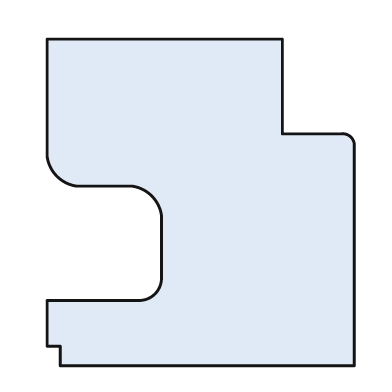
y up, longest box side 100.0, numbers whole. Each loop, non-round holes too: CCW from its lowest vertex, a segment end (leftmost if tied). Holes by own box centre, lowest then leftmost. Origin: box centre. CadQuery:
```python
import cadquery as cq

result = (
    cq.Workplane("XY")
    .moveTo(-43.0, -50.0)
    .lineTo(47.0, -50.0)
    .lineTo(47.0, 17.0)
    .threePointArc((46.0, 20.0), (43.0, 21.0))
    .lineTo(25.0, 21.0)
    .lineTo(25.0, 50.0)
    .lineTo(-47.0, 50.0)
    .lineTo(-47.0, 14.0)
    .threePointArc((-44.0, 8.0), (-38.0, 5.0))
    .lineTo(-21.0, 5.0)
    .threePointArc((-15.0, 2.0), (-12.0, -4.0))
    .lineTo(-12.0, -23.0)
    .threePointArc((-14.0, -28.0), (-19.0, -30.0))
    .lineTo(-47.0, -30.0)
    .lineTo(-47.0, -44.0)
    .lineTo(-43.0, -44.0)
    .close()
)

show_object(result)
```